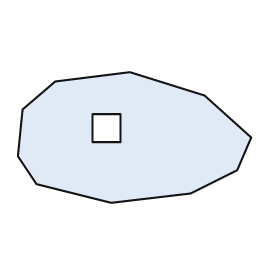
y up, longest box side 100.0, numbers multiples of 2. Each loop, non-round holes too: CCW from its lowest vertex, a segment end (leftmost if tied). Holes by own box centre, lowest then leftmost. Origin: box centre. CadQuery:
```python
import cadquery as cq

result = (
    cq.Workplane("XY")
    .moveTo(-10.0, -28.0)
    .lineTo(24.0, -24.0)
    .lineTo(44.0, -14.0)
    .lineTo(50.0, 0.0)
    .lineTo(30.0, 18.0)
    .lineTo(-2.0, 28.0)
    .lineTo(-34.0, 24.0)
    .lineTo(-48.0, 12.0)
    .lineTo(-50.0, -8.0)
    .lineTo(-42.0, -20.0)
    .close()
    .moveTo(-18.0, -2.0)
    .lineTo(-6.0, -2.0)
    .lineTo(-6.0, 10.0)
    .lineTo(-18.0, 10.0)
    .close()
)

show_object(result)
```